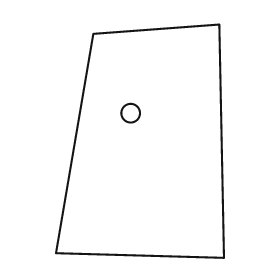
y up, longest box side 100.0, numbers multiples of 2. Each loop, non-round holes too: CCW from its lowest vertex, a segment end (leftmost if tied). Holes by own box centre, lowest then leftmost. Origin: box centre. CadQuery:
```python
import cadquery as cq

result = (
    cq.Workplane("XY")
    .moveTo(36.0, -50.0)
    .lineTo(34.0, 50.0)
    .lineTo(-20.0, 46.0)
    .lineTo(-36.0, -48.0)
    .close()
    .moveTo(-4.0, 12.0)
    .circle(4.0)
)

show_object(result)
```